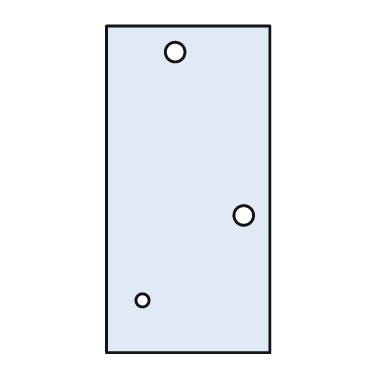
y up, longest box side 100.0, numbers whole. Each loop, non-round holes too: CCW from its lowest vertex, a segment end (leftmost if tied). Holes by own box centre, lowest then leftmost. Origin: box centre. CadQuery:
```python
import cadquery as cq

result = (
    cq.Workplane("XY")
    .moveTo(-25.0, -50.0)
    .lineTo(25.0, -50.0)
    .lineTo(25.0, 50.0)
    .lineTo(-25.0, 50.0)
    .close()
    .moveTo(-14.0, -34.0)
    .circle(2.0)
    .moveTo(17.0, -8.0)
    .circle(3.0)
    .moveTo(-4.0, 42.0)
    .circle(3.0)
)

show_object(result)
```